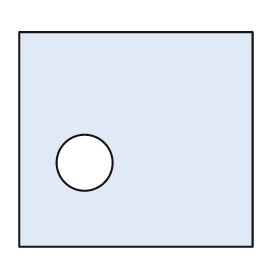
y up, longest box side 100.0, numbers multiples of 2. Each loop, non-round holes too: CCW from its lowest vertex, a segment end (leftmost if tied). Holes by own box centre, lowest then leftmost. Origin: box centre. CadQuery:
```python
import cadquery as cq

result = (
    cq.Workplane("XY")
    .moveTo(-50.0, -46.0)
    .lineTo(50.0, -46.0)
    .lineTo(50.0, 46.0)
    .lineTo(-50.0, 46.0)
    .close()
    .moveTo(-22.0, -10.0)
    .circle(12.0)
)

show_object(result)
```